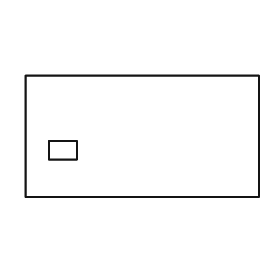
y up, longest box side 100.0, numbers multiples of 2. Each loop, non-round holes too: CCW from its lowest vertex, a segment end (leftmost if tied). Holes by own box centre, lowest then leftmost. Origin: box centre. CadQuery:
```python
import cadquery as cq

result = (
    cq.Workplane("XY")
    .moveTo(-50.0, -26.0)
    .lineTo(50.0, -26.0)
    .lineTo(50.0, 26.0)
    .lineTo(-50.0, 26.0)
    .close()
    .moveTo(-40.0, -10.0)
    .lineTo(-28.0, -10.0)
    .lineTo(-28.0, -2.0)
    .lineTo(-40.0, -2.0)
    .close()
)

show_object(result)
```